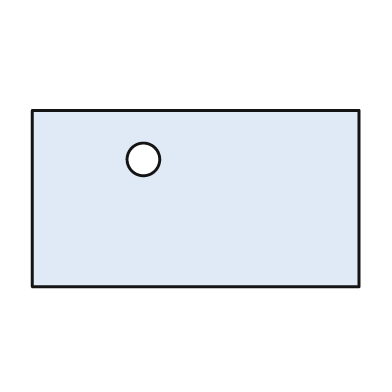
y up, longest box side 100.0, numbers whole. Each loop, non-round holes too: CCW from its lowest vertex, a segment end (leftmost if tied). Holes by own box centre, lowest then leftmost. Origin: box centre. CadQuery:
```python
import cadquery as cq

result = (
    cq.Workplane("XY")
    .moveTo(-50.0, -27.0)
    .lineTo(50.0, -27.0)
    .lineTo(50.0, 27.0)
    .lineTo(-50.0, 27.0)
    .close()
    .moveTo(-16.0, 12.0)
    .circle(5.0)
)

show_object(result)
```